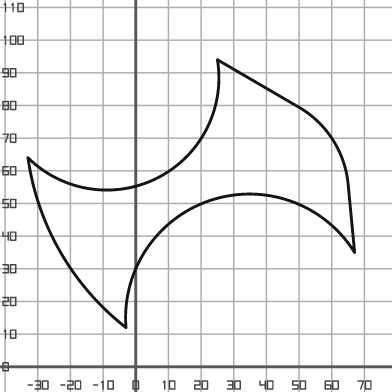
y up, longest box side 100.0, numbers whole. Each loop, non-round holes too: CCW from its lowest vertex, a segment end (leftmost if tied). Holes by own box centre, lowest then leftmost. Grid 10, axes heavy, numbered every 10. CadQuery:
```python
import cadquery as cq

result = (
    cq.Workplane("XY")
    .moveTo(-3.0, 12.0)
    .threePointArc((23.0, 51.0), (67.0, 35.0))
    .lineTo(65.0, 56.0)
    .threePointArc((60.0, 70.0), (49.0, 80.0))
    .lineTo(25.0, 94.0)
    .threePointArc((7.0, 58.0), (-33.0, 64.0))
    .threePointArc((-23.0, 35.0), (-3.0, 12.0))
    .close()
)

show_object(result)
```